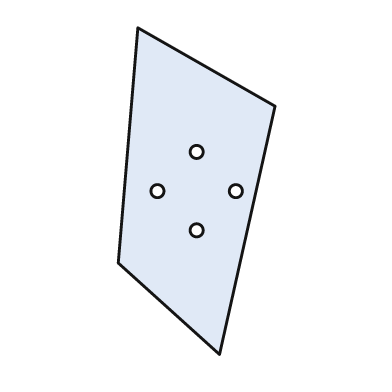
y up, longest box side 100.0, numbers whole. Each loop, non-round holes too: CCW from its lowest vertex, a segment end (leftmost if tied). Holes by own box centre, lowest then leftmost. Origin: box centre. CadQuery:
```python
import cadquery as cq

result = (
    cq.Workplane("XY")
    .moveTo(7.0, -50.0)
    .lineTo(24.0, 26.0)
    .lineTo(-18.0, 50.0)
    .lineTo(-24.0, -22.0)
    .close()
    .moveTo(0.0, -12.0)
    .circle(2.0)
    .moveTo(-12.0, 0.0)
    .circle(2.0)
    .moveTo(12.0, 0.0)
    .circle(2.0)
    .moveTo(0.0, 12.0)
    .circle(2.0)
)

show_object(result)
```